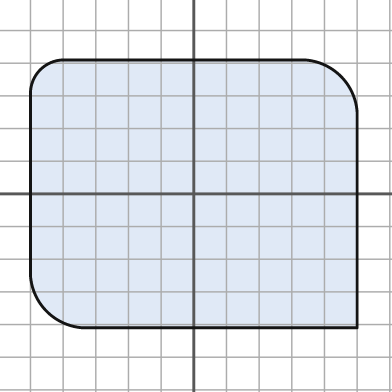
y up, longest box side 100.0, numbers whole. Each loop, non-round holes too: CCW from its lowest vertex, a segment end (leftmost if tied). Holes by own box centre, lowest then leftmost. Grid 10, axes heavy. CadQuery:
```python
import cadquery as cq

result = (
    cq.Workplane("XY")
    .moveTo(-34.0, -41.0)
    .lineTo(50.0, -41.0)
    .lineTo(50.0, 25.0)
    .threePointArc((45.0, 36.0), (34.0, 41.0))
    .lineTo(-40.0, 41.0)
    .threePointArc((-47.0, 38.0), (-50.0, 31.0))
    .lineTo(-50.0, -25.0)
    .threePointArc((-45.0, -36.0), (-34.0, -41.0))
    .close()
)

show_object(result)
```